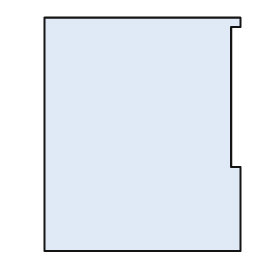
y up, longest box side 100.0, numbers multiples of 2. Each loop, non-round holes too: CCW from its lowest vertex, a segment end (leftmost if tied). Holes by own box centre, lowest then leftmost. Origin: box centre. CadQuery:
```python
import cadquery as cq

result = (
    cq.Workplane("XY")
    .moveTo(-42.0, -50.0)
    .lineTo(42.0, -50.0)
    .lineTo(42.0, -14.0)
    .lineTo(38.0, -14.0)
    .lineTo(38.0, 46.0)
    .lineTo(42.0, 46.0)
    .lineTo(42.0, 50.0)
    .lineTo(-42.0, 50.0)
    .close()
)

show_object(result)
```